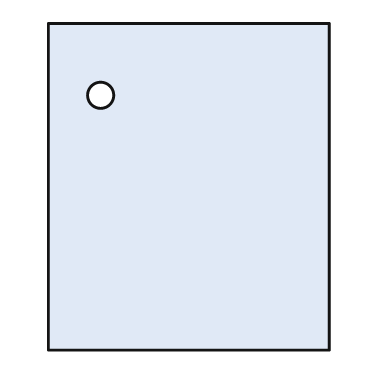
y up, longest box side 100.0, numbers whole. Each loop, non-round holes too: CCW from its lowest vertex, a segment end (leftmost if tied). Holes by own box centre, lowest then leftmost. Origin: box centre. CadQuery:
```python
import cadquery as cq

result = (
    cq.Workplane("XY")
    .moveTo(-43.0, -50.0)
    .lineTo(43.0, -50.0)
    .lineTo(43.0, 50.0)
    .lineTo(-43.0, 50.0)
    .close()
    .moveTo(-27.0, 28.0)
    .circle(4.0)
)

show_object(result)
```